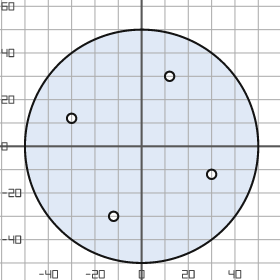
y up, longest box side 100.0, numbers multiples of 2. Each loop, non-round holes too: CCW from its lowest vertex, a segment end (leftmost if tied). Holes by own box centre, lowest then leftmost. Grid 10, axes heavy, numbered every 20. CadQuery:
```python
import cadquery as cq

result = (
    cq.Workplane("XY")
    .moveTo(0.0, 0.0)
    .circle(50.0)
    .moveTo(-12.0, -30.0)
    .circle(2.0)
    .moveTo(30.0, -12.0)
    .circle(2.0)
    .moveTo(-30.0, 12.0)
    .circle(2.0)
    .moveTo(12.0, 30.0)
    .circle(2.0)
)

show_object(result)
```